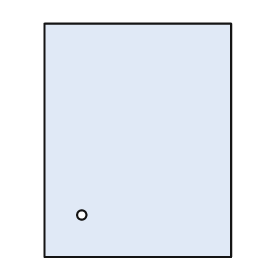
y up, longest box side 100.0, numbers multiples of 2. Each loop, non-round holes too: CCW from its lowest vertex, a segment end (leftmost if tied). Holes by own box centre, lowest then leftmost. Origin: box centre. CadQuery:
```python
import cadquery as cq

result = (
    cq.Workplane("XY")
    .moveTo(-40.0, -50.0)
    .lineTo(40.0, -50.0)
    .lineTo(40.0, 50.0)
    .lineTo(-40.0, 50.0)
    .close()
    .moveTo(-24.0, -32.0)
    .circle(2.0)
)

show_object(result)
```